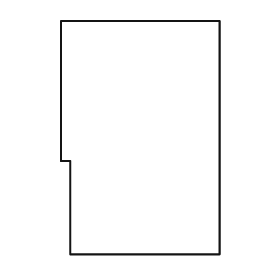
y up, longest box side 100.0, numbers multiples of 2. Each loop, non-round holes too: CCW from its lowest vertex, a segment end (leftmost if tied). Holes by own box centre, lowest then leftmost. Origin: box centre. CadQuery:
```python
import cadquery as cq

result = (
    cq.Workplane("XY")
    .moveTo(-30.0, -50.0)
    .lineTo(34.0, -50.0)
    .lineTo(34.0, 50.0)
    .lineTo(-34.0, 50.0)
    .lineTo(-34.0, -10.0)
    .lineTo(-30.0, -10.0)
    .close()
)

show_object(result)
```